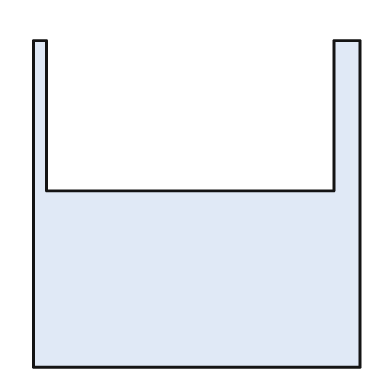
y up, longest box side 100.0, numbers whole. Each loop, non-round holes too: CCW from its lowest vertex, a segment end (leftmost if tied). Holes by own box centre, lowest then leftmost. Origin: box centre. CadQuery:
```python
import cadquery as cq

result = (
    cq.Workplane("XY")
    .moveTo(-50.0, -50.0)
    .lineTo(50.0, -50.0)
    .lineTo(50.0, 50.0)
    .lineTo(42.0, 50.0)
    .lineTo(42.0, 4.0)
    .lineTo(-46.0, 4.0)
    .lineTo(-46.0, 50.0)
    .lineTo(-50.0, 50.0)
    .close()
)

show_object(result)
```